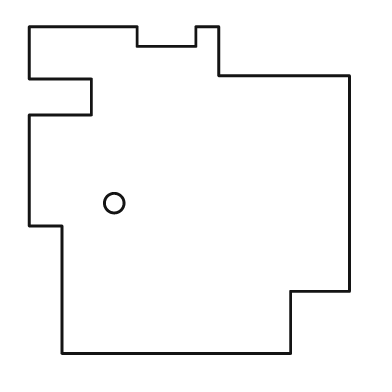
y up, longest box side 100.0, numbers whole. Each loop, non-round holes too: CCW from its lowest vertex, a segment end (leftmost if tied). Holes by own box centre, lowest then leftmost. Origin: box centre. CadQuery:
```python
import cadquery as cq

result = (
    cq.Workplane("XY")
    .moveTo(-39.0, -50.0)
    .lineTo(31.0, -50.0)
    .lineTo(31.0, -31.0)
    .lineTo(49.0, -31.0)
    .lineTo(49.0, 35.0)
    .lineTo(9.0, 35.0)
    .lineTo(9.0, 50.0)
    .lineTo(2.0, 50.0)
    .lineTo(2.0, 44.0)
    .lineTo(-16.0, 44.0)
    .lineTo(-16.0, 50.0)
    .lineTo(-49.0, 50.0)
    .lineTo(-49.0, 34.0)
    .lineTo(-30.0, 34.0)
    .lineTo(-30.0, 23.0)
    .lineTo(-49.0, 23.0)
    .lineTo(-49.0, -11.0)
    .lineTo(-39.0, -11.0)
    .close()
    .moveTo(-23.0, -4.0)
    .circle(3.0)
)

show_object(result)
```